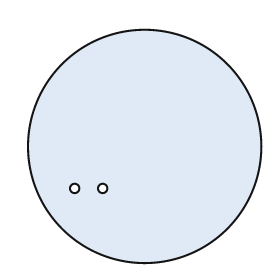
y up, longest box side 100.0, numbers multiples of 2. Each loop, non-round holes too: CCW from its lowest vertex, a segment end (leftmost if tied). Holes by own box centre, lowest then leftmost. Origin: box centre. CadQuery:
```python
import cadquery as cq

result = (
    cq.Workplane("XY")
    .moveTo(0.0, 0.0)
    .circle(50.0)
    .moveTo(-30.0, -18.0)
    .circle(2.0)
    .moveTo(-18.0, -18.0)
    .circle(2.0)
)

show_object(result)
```